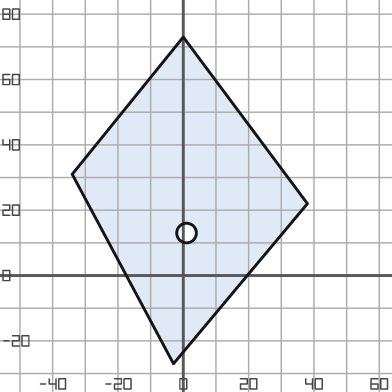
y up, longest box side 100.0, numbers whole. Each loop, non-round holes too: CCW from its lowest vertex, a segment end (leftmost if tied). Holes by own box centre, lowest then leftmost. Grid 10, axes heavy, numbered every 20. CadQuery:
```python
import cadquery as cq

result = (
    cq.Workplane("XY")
    .moveTo(-3.0, -27.0)
    .lineTo(38.0, 22.0)
    .lineTo(0.0, 73.0)
    .lineTo(-34.0, 31.0)
    .close()
    .moveTo(1.0, 13.0)
    .circle(3.0)
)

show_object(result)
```